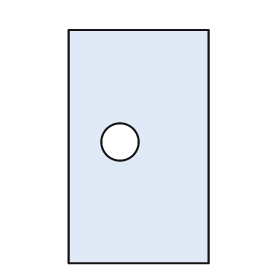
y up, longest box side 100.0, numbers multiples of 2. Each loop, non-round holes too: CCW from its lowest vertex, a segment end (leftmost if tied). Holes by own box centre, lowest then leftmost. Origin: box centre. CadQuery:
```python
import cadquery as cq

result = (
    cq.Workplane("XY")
    .moveTo(-30.0, -50.0)
    .lineTo(30.0, -50.0)
    .lineTo(30.0, 50.0)
    .lineTo(-30.0, 50.0)
    .close()
    .moveTo(-8.0, 2.0)
    .circle(8.0)
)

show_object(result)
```